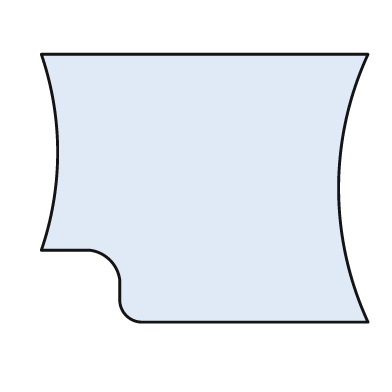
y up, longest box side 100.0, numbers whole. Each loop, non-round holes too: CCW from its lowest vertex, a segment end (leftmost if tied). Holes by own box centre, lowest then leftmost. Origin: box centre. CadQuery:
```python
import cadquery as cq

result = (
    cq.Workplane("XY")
    .moveTo(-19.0, -41.0)
    .lineTo(50.0, -41.0)
    .threePointArc((41.0, 0.0), (50.0, 41.0))
    .lineTo(-50.0, 41.0)
    .threePointArc((-45.0, 11.0), (-50.0, -19.0))
    .lineTo(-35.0, -19.0)
    .threePointArc((-29.0, -22.0), (-26.0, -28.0))
    .lineTo(-26.0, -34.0)
    .threePointArc((-24.0, -39.0), (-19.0, -41.0))
    .close()
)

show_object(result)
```